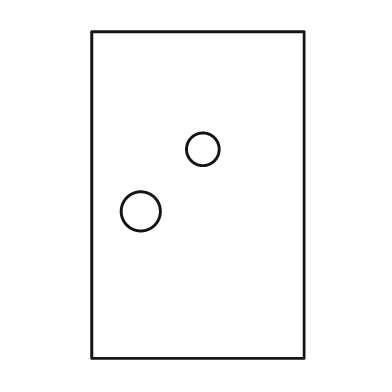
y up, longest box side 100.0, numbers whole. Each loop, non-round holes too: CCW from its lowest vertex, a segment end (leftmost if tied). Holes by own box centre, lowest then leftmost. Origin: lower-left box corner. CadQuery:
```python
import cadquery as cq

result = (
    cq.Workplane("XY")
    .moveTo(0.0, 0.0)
    .lineTo(65.0, 0.0)
    .lineTo(65.0, 100.0)
    .lineTo(0.0, 100.0)
    .close()
    .moveTo(15.0, 45.0)
    .circle(6.0)
    .moveTo(34.0, 64.0)
    .circle(5.0)
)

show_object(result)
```